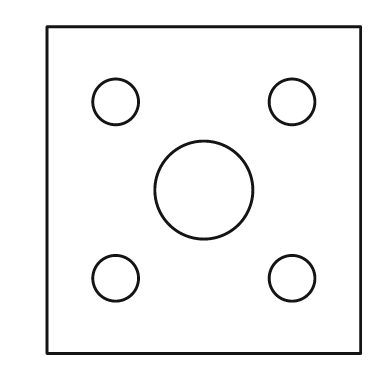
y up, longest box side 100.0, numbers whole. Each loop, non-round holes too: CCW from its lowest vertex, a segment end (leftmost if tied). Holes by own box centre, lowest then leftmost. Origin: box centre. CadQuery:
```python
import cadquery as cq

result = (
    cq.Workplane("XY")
    .moveTo(-48.0, -50.0)
    .lineTo(48.0, -50.0)
    .lineTo(48.0, 50.0)
    .lineTo(-48.0, 50.0)
    .close()
    .moveTo(-27.0, -27.0)
    .circle(7.0)
    .moveTo(27.0, -27.0)
    .circle(7.0)
    .moveTo(0.0, 0.0)
    .circle(15.0)
    .moveTo(-27.0, 27.0)
    .circle(7.0)
    .moveTo(27.0, 27.0)
    .circle(7.0)
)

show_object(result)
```